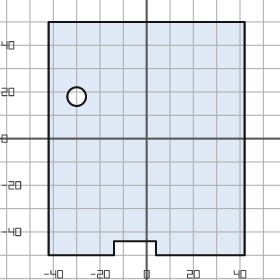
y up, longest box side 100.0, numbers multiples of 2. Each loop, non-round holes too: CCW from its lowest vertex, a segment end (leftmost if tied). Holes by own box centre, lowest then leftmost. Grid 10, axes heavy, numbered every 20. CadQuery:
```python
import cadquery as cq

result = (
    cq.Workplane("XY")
    .moveTo(-42.0, -50.0)
    .lineTo(-14.0, -50.0)
    .lineTo(-14.0, -44.0)
    .lineTo(4.0, -44.0)
    .lineTo(4.0, -50.0)
    .lineTo(42.0, -50.0)
    .lineTo(42.0, 50.0)
    .lineTo(-42.0, 50.0)
    .close()
    .moveTo(-30.0, 18.0)
    .circle(4.0)
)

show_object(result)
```